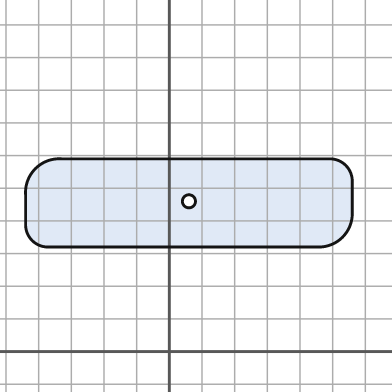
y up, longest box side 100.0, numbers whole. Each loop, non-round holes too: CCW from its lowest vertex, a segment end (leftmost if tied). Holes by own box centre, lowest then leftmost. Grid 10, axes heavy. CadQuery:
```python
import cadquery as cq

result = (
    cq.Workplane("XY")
    .moveTo(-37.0, 32.0)
    .lineTo(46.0, 32.0)
    .threePointArc((53.0, 35.0), (56.0, 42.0))
    .lineTo(56.0, 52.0)
    .threePointArc((54.0, 57.0), (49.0, 59.0))
    .lineTo(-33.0, 59.0)
    .threePointArc((-41.0, 56.0), (-44.0, 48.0))
    .lineTo(-44.0, 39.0)
    .threePointArc((-42.0, 34.0), (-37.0, 32.0))
    .close()
    .moveTo(6.0, 46.0)
    .circle(2.0)
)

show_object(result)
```